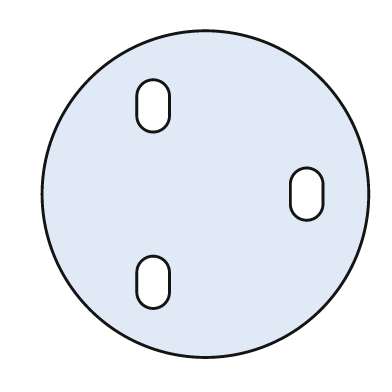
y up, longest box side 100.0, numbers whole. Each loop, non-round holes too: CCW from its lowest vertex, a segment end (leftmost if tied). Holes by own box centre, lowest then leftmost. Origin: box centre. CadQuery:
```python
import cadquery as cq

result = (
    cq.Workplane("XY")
    .moveTo(0.0, 0.0)
    .circle(50.0)
    .moveTo(-21.0, -30.0)
    .threePointArc((-16.0, -35.0), (-11.0, -30.0))
    .lineTo(-11.0, -24.0)
    .threePointArc((-16.0, -19.0), (-21.0, -24.0))
    .close()
    .moveTo(26.0, -3.0)
    .threePointArc((31.0, -8.0), (36.0, -3.0))
    .lineTo(36.0, 3.0)
    .threePointArc((31.0, 8.0), (26.0, 3.0))
    .close()
    .moveTo(-21.0, 24.0)
    .threePointArc((-16.0, 19.0), (-11.0, 24.0))
    .lineTo(-11.0, 30.0)
    .threePointArc((-16.0, 35.0), (-21.0, 30.0))
    .close()
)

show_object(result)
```